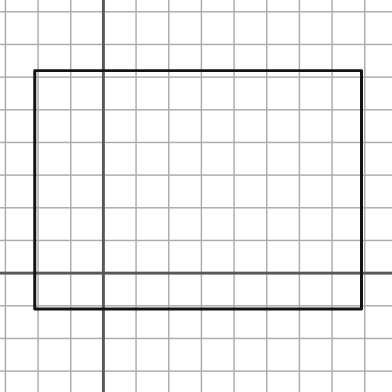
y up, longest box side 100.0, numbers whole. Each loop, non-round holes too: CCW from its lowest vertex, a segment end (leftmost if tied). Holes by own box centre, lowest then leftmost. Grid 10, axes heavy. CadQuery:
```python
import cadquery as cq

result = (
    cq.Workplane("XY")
    .moveTo(-21.0, -11.0)
    .lineTo(79.0, -11.0)
    .lineTo(79.0, 62.0)
    .lineTo(-21.0, 62.0)
    .close()
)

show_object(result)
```